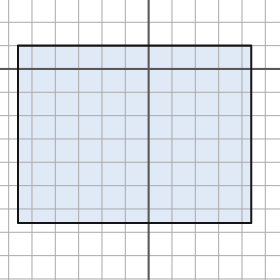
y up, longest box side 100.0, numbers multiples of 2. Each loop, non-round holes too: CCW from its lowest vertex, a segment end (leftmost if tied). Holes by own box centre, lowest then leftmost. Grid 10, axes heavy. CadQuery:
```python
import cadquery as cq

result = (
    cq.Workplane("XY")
    .moveTo(-56.0, -66.0)
    .lineTo(44.0, -66.0)
    .lineTo(44.0, 10.0)
    .lineTo(-56.0, 10.0)
    .close()
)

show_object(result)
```